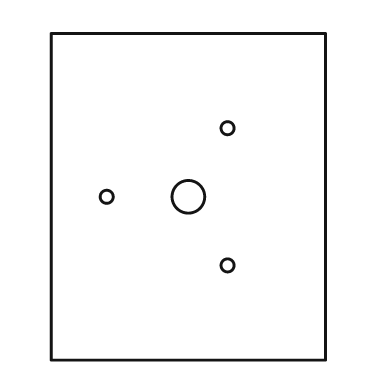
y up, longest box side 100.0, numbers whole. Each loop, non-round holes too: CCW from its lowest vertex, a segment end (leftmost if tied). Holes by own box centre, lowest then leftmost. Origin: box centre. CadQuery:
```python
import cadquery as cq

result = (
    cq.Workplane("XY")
    .moveTo(-42.0, -50.0)
    .lineTo(42.0, -50.0)
    .lineTo(42.0, 50.0)
    .lineTo(-42.0, 50.0)
    .close()
    .moveTo(12.0, -21.0)
    .circle(2.0)
    .moveTo(-25.0, 0.0)
    .circle(2.0)
    .moveTo(0.0, 0.0)
    .circle(5.0)
    .moveTo(12.0, 21.0)
    .circle(2.0)
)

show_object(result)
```